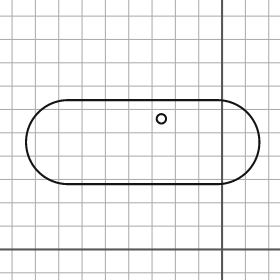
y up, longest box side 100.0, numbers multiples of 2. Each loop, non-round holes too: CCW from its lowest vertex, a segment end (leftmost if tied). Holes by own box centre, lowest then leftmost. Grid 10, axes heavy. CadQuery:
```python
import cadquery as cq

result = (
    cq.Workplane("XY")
    .moveTo(-66.0, 28.0)
    .lineTo(-2.0, 28.0)
    .threePointArc((16.0, 46.0), (-2.0, 64.0))
    .lineTo(-66.0, 64.0)
    .threePointArc((-84.0, 46.0), (-66.0, 28.0))
    .close()
    .moveTo(-26.0, 56.0)
    .circle(2.0)
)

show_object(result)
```